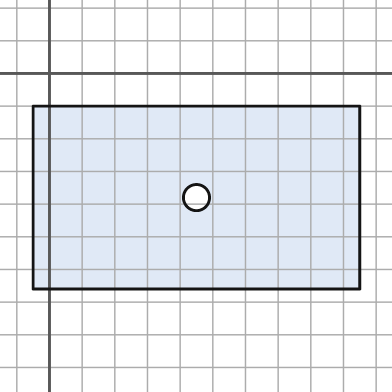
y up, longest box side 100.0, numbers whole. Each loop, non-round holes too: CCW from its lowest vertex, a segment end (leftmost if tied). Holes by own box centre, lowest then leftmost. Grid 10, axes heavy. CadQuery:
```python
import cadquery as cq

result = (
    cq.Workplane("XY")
    .moveTo(-5.0, -66.0)
    .lineTo(95.0, -66.0)
    .lineTo(95.0, -10.0)
    .lineTo(-5.0, -10.0)
    .close()
    .moveTo(45.0, -38.0)
    .circle(4.0)
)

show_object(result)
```